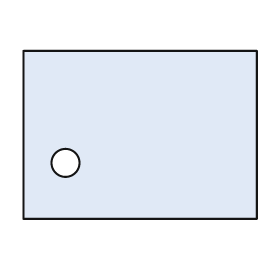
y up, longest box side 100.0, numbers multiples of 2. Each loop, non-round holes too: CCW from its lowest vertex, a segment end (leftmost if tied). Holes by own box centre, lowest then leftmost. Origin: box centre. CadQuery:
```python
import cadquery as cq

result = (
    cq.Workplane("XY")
    .moveTo(-50.0, -36.0)
    .lineTo(50.0, -36.0)
    .lineTo(50.0, 36.0)
    .lineTo(-50.0, 36.0)
    .close()
    .moveTo(-32.0, -12.0)
    .circle(6.0)
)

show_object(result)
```